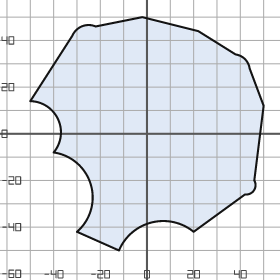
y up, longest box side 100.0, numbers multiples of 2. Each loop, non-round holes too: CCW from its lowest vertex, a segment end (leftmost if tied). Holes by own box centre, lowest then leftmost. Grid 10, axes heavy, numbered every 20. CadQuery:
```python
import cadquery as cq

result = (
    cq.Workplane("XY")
    .moveTo(-12.0, -50.0)
    .threePointArc((2.0, -38.0), (20.0, -42.0))
    .lineTo(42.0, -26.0)
    .threePointArc((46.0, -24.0), (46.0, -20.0))
    .lineTo(50.0, 12.0)
    .lineTo(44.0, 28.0)
    .threePointArc((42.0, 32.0), (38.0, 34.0))
    .lineTo(22.0, 44.0)
    .lineTo(-2.0, 50.0)
    .lineTo(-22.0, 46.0)
    .threePointArc((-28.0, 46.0), (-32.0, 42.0))
    .lineTo(-50.0, 14.0)
    .threePointArc((-38.0, 6.0), (-40.0, -8.0))
    .threePointArc((-24.0, -22.0), (-30.0, -42.0))
    .close()
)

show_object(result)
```